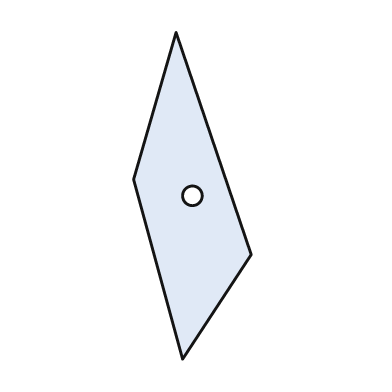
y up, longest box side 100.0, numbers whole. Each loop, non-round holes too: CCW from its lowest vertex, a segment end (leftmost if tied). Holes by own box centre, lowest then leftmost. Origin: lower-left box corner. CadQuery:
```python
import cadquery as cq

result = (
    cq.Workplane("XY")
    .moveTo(15.0, 0.0)
    .lineTo(36.0, 32.0)
    .lineTo(13.0, 100.0)
    .lineTo(0.0, 55.0)
    .close()
    .moveTo(18.0, 50.0)
    .circle(3.0)
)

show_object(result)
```